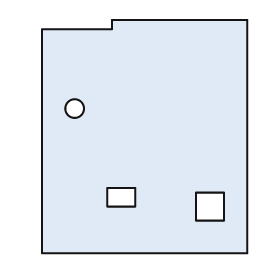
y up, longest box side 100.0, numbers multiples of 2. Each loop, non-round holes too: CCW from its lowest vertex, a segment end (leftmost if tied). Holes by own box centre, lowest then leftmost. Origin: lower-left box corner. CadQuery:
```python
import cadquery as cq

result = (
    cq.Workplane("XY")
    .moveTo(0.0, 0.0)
    .lineTo(88.0, 0.0)
    .lineTo(88.0, 100.0)
    .lineTo(30.0, 100.0)
    .lineTo(30.0, 96.0)
    .lineTo(0.0, 96.0)
    .close()
    .moveTo(66.0, 14.0)
    .lineTo(78.0, 14.0)
    .lineTo(78.0, 26.0)
    .lineTo(66.0, 26.0)
    .close()
    .moveTo(28.0, 20.0)
    .lineTo(40.0, 20.0)
    .lineTo(40.0, 28.0)
    .lineTo(28.0, 28.0)
    .close()
    .moveTo(14.0, 62.0)
    .circle(4.0)
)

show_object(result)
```